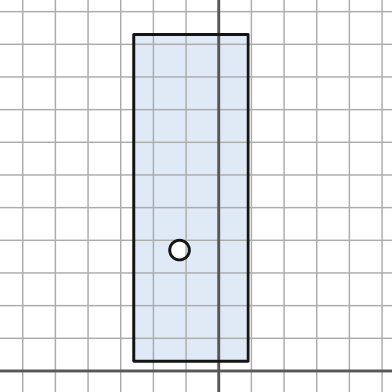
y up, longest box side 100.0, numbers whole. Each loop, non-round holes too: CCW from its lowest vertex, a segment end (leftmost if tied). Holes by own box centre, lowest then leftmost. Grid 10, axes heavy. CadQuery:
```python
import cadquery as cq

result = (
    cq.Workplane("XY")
    .moveTo(-26.0, 3.0)
    .lineTo(9.0, 3.0)
    .lineTo(9.0, 103.0)
    .lineTo(-26.0, 103.0)
    .close()
    .moveTo(-12.0, 37.0)
    .circle(3.0)
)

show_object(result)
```